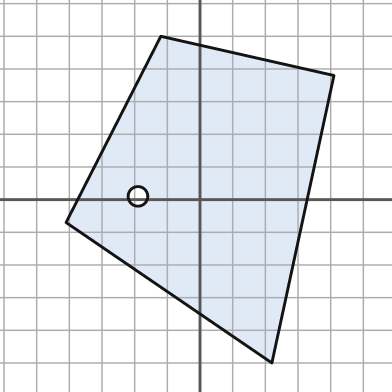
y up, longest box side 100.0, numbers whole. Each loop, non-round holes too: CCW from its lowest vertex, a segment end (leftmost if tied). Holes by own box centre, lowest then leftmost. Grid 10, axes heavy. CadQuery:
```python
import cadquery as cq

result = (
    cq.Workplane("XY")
    .moveTo(22.0, -50.0)
    .lineTo(41.0, 38.0)
    .lineTo(-12.0, 50.0)
    .lineTo(-41.0, -7.0)
    .close()
    .moveTo(-19.0, 1.0)
    .circle(3.0)
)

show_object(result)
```